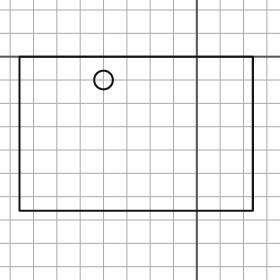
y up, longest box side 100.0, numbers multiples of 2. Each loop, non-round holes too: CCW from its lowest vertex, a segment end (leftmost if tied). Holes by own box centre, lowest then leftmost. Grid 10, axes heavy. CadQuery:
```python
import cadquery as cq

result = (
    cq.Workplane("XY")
    .moveTo(-76.0, -66.0)
    .lineTo(24.0, -66.0)
    .lineTo(24.0, 0.0)
    .lineTo(-76.0, 0.0)
    .close()
    .moveTo(-40.0, -10.0)
    .circle(4.0)
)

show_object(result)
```